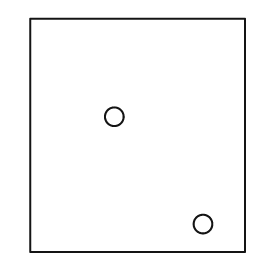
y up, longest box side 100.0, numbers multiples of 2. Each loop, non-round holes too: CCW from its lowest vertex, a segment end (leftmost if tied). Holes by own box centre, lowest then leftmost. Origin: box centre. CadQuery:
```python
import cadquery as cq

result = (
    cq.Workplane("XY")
    .moveTo(-46.0, -50.0)
    .lineTo(46.0, -50.0)
    .lineTo(46.0, 50.0)
    .lineTo(-46.0, 50.0)
    .close()
    .moveTo(28.0, -38.0)
    .circle(4.0)
    .moveTo(-10.0, 8.0)
    .circle(4.0)
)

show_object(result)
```